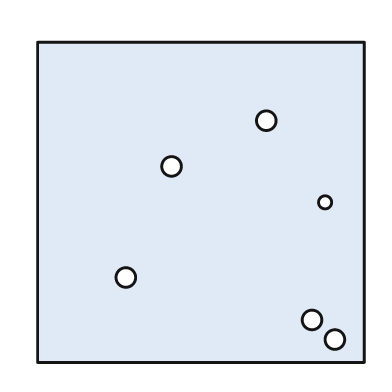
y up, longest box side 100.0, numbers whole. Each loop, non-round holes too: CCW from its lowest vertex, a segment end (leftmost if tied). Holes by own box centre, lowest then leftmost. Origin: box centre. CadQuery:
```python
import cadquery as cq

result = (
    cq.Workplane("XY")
    .moveTo(-50.0, -49.0)
    .lineTo(50.0, -49.0)
    .lineTo(50.0, 49.0)
    .lineTo(-50.0, 49.0)
    .close()
    .moveTo(41.0, -42.0)
    .circle(3.0)
    .moveTo(34.0, -36.0)
    .circle(3.0)
    .moveTo(-23.0, -23.0)
    .circle(3.0)
    .moveTo(38.0, 0.0)
    .circle(2.0)
    .moveTo(-9.0, 11.0)
    .circle(3.0)
    .moveTo(20.0, 25.0)
    .circle(3.0)
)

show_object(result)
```